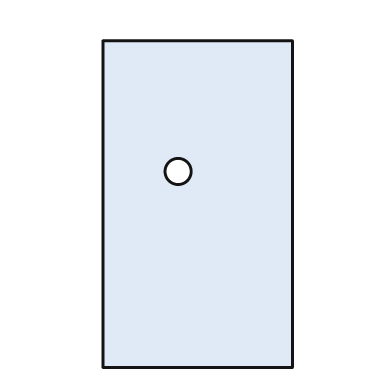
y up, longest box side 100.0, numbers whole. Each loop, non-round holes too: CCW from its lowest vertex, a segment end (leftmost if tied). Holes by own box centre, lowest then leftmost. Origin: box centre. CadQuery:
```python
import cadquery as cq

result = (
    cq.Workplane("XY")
    .moveTo(-29.0, -50.0)
    .lineTo(29.0, -50.0)
    .lineTo(29.0, 50.0)
    .lineTo(-29.0, 50.0)
    .close()
    .moveTo(-6.0, 10.0)
    .circle(4.0)
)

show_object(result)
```